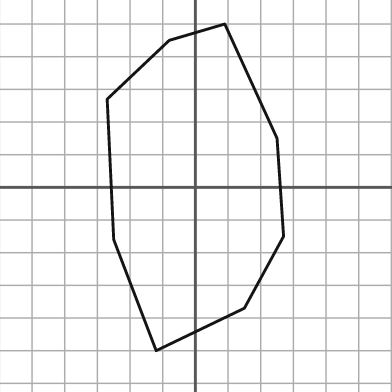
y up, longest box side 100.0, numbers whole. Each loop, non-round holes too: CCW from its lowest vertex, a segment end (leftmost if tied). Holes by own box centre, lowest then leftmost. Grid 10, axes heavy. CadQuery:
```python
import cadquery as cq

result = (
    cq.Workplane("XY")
    .moveTo(-12.0, -50.0)
    .lineTo(15.0, -37.0)
    .lineTo(27.0, -15.0)
    .lineTo(25.0, 15.0)
    .lineTo(9.0, 50.0)
    .lineTo(-8.0, 45.0)
    .lineTo(-27.0, 27.0)
    .lineTo(-25.0, -16.0)
    .close()
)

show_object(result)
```